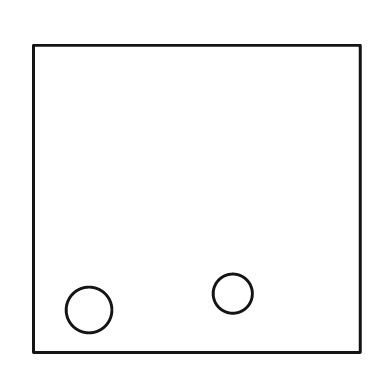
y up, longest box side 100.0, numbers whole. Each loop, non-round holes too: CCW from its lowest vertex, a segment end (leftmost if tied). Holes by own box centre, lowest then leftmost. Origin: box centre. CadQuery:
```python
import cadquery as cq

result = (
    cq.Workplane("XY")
    .moveTo(-50.0, -47.0)
    .lineTo(50.0, -47.0)
    .lineTo(50.0, 47.0)
    .lineTo(-50.0, 47.0)
    .close()
    .moveTo(-33.0, -34.0)
    .circle(7.0)
    .moveTo(11.0, -29.0)
    .circle(6.0)
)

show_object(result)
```